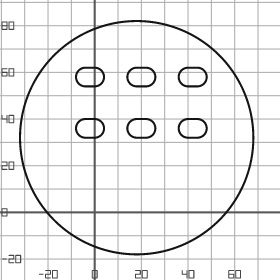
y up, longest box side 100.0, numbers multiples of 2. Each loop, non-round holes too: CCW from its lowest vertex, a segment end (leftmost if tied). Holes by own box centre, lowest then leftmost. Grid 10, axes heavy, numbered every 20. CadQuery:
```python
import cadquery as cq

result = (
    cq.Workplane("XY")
    .moveTo(18.0, 32.0)
    .circle(50.0)
    .moveTo(-4.0, 32.0)
    .lineTo(0.0, 32.0)
    .threePointArc((4.0, 36.0), (0.0, 40.0))
    .lineTo(-4.0, 40.0)
    .threePointArc((-8.0, 36.0), (-4.0, 32.0))
    .close()
    .moveTo(18.0, 32.0)
    .lineTo(22.0, 32.0)
    .threePointArc((26.0, 36.0), (22.0, 40.0))
    .lineTo(18.0, 40.0)
    .threePointArc((14.0, 36.0), (18.0, 32.0))
    .close()
    .moveTo(40.0, 32.0)
    .lineTo(44.0, 32.0)
    .threePointArc((48.0, 36.0), (44.0, 40.0))
    .lineTo(40.0, 40.0)
    .threePointArc((36.0, 36.0), (40.0, 32.0))
    .close()
    .moveTo(-4.0, 54.0)
    .lineTo(0.0, 54.0)
    .threePointArc((4.0, 58.0), (0.0, 62.0))
    .lineTo(-4.0, 62.0)
    .threePointArc((-8.0, 58.0), (-4.0, 54.0))
    .close()
    .moveTo(18.0, 54.0)
    .lineTo(22.0, 54.0)
    .threePointArc((26.0, 58.0), (22.0, 62.0))
    .lineTo(18.0, 62.0)
    .threePointArc((14.0, 58.0), (18.0, 54.0))
    .close()
    .moveTo(40.0, 54.0)
    .lineTo(44.0, 54.0)
    .threePointArc((48.0, 58.0), (44.0, 62.0))
    .lineTo(40.0, 62.0)
    .threePointArc((36.0, 58.0), (40.0, 54.0))
    .close()
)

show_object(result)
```